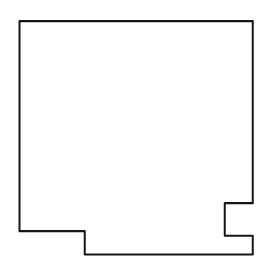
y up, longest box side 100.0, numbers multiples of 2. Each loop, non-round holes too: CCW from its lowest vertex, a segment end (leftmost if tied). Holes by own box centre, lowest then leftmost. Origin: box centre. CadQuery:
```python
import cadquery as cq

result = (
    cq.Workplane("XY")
    .moveTo(-22.0, -50.0)
    .lineTo(50.0, -50.0)
    .lineTo(50.0, -42.0)
    .lineTo(38.0, -42.0)
    .lineTo(38.0, -28.0)
    .lineTo(50.0, -28.0)
    .lineTo(50.0, 50.0)
    .lineTo(-50.0, 50.0)
    .lineTo(-50.0, -40.0)
    .lineTo(-22.0, -40.0)
    .close()
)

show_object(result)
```